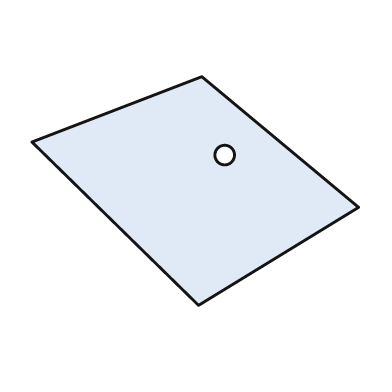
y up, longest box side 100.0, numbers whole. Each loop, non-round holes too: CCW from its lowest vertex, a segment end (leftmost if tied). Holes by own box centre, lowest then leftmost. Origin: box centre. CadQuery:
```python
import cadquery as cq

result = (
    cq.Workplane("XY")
    .moveTo(1.0, -35.0)
    .lineTo(50.0, -5.0)
    .lineTo(2.0, 35.0)
    .lineTo(-50.0, 15.0)
    .close()
    .moveTo(9.0, 11.0)
    .circle(3.0)
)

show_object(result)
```